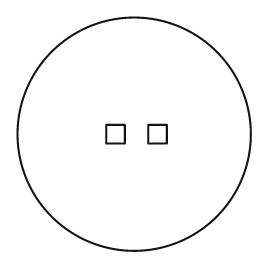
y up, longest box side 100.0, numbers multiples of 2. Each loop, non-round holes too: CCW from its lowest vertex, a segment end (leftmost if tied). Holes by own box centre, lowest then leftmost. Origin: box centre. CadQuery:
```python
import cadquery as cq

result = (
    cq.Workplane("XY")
    .moveTo(0.0, 0.0)
    .circle(50.0)
    .moveTo(-12.0, -4.0)
    .lineTo(-4.0, -4.0)
    .lineTo(-4.0, 4.0)
    .lineTo(-12.0, 4.0)
    .close()
    .moveTo(6.0, -4.0)
    .lineTo(14.0, -4.0)
    .lineTo(14.0, 4.0)
    .lineTo(6.0, 4.0)
    .close()
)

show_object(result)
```